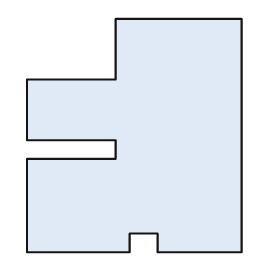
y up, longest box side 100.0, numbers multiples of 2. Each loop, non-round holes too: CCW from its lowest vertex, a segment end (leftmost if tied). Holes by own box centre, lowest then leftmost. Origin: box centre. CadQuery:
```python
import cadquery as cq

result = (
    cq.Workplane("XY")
    .moveTo(-46.0, -50.0)
    .lineTo(-2.0, -50.0)
    .lineTo(-2.0, -42.0)
    .lineTo(10.0, -42.0)
    .lineTo(10.0, -50.0)
    .lineTo(46.0, -50.0)
    .lineTo(46.0, 50.0)
    .lineTo(-8.0, 50.0)
    .lineTo(-8.0, 24.0)
    .lineTo(-46.0, 24.0)
    .lineTo(-46.0, -2.0)
    .lineTo(-8.0, -2.0)
    .lineTo(-8.0, -10.0)
    .lineTo(-46.0, -10.0)
    .close()
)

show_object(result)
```